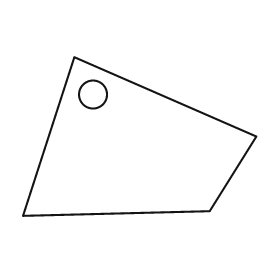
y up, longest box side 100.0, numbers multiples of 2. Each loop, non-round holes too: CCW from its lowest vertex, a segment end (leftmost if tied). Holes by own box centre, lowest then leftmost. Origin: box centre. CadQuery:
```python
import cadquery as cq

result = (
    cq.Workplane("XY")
    .moveTo(-50.0, -34.0)
    .lineTo(30.0, -32.0)
    .lineTo(50.0, 0.0)
    .lineTo(-28.0, 34.0)
    .close()
    .moveTo(-20.0, 18.0)
    .circle(6.0)
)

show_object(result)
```